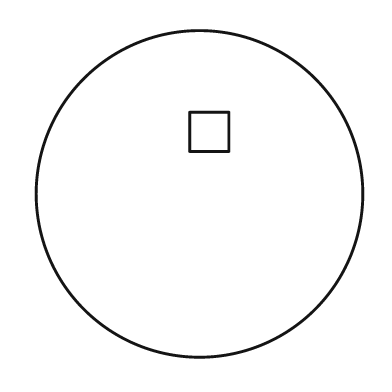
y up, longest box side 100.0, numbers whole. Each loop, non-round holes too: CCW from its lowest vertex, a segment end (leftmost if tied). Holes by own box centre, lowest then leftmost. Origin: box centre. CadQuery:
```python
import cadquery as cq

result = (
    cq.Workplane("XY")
    .moveTo(0.0, 0.0)
    .circle(50.0)
    .moveTo(-3.0, 13.0)
    .lineTo(9.0, 13.0)
    .lineTo(9.0, 25.0)
    .lineTo(-3.0, 25.0)
    .close()
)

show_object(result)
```